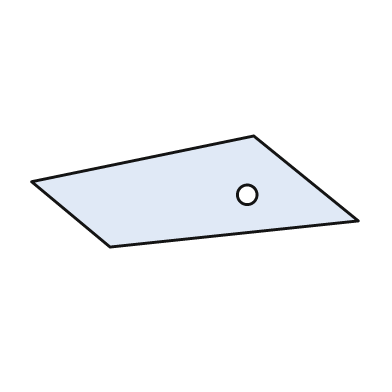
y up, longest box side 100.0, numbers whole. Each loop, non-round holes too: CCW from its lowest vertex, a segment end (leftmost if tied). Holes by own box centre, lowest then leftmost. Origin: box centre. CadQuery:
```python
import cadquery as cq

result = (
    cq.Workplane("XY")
    .moveTo(-26.0, -17.0)
    .lineTo(50.0, -9.0)
    .lineTo(18.0, 17.0)
    .lineTo(-50.0, 3.0)
    .close()
    .moveTo(16.0, -1.0)
    .circle(3.0)
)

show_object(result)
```